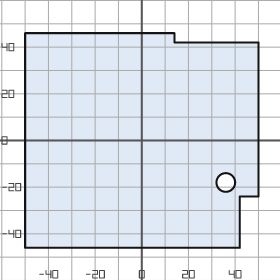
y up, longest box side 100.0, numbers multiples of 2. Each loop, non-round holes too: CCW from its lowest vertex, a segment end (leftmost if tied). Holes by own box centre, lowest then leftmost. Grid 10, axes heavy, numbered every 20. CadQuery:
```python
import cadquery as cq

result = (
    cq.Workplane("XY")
    .moveTo(-50.0, -46.0)
    .lineTo(42.0, -46.0)
    .lineTo(42.0, -24.0)
    .lineTo(50.0, -24.0)
    .lineTo(50.0, 42.0)
    .lineTo(14.0, 42.0)
    .lineTo(14.0, 46.0)
    .lineTo(-50.0, 46.0)
    .close()
    .moveTo(36.0, -18.0)
    .circle(4.0)
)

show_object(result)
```